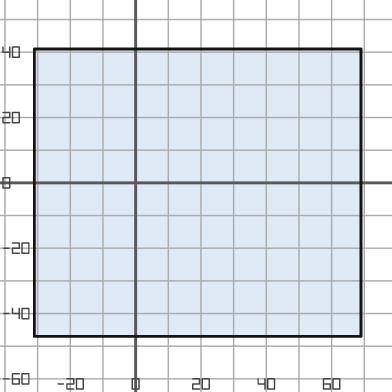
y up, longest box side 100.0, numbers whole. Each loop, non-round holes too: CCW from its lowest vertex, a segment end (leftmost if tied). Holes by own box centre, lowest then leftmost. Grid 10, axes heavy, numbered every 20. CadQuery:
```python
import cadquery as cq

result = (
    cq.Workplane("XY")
    .moveTo(-31.0, -47.0)
    .lineTo(69.0, -47.0)
    .lineTo(69.0, 41.0)
    .lineTo(-31.0, 41.0)
    .close()
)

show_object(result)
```